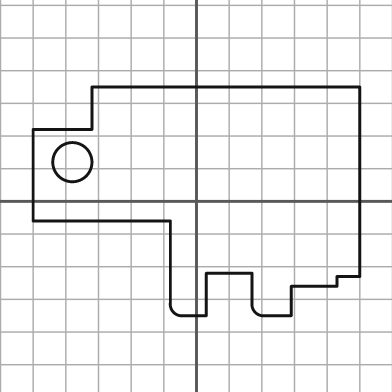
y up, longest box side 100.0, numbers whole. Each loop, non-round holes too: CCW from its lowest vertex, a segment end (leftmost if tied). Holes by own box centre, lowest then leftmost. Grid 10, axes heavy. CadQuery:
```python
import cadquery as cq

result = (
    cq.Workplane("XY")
    .moveTo(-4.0, -35.0)
    .lineTo(3.0, -35.0)
    .lineTo(3.0, -22.0)
    .lineTo(17.0, -22.0)
    .lineTo(17.0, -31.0)
    .threePointArc((18.0, -34.0), (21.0, -35.0))
    .lineTo(29.0, -35.0)
    .lineTo(29.0, -26.0)
    .lineTo(43.0, -26.0)
    .lineTo(43.0, -23.0)
    .lineTo(50.0, -23.0)
    .lineTo(50.0, 35.0)
    .lineTo(-32.0, 35.0)
    .lineTo(-32.0, 22.0)
    .lineTo(-50.0, 22.0)
    .lineTo(-50.0, -6.0)
    .lineTo(-8.0, -6.0)
    .lineTo(-8.0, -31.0)
    .threePointArc((-7.0, -34.0), (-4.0, -35.0))
    .close()
    .moveTo(-38.0, 12.0)
    .circle(6.0)
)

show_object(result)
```